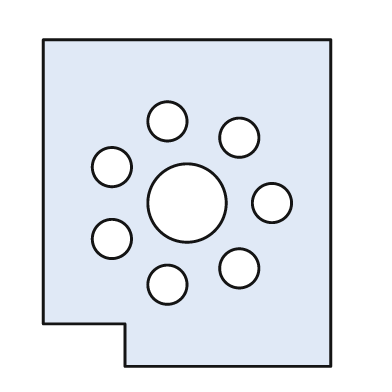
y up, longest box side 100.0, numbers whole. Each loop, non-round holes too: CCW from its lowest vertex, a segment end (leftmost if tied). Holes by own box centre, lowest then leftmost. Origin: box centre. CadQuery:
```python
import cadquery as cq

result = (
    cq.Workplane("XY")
    .moveTo(-19.0, -50.0)
    .lineTo(44.0, -50.0)
    .lineTo(44.0, 50.0)
    .lineTo(-44.0, 50.0)
    .lineTo(-44.0, -37.0)
    .lineTo(-19.0, -37.0)
    .close()
    .moveTo(-6.0, -25.0)
    .circle(6.0)
    .moveTo(16.0, -20.0)
    .circle(6.0)
    .moveTo(-23.0, -11.0)
    .circle(6.0)
    .moveTo(0.0, 0.0)
    .circle(12.0)
    .moveTo(26.0, 0.0)
    .circle(6.0)
    .moveTo(-23.0, 11.0)
    .circle(6.0)
    .moveTo(16.0, 20.0)
    .circle(6.0)
    .moveTo(-6.0, 25.0)
    .circle(6.0)
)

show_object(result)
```